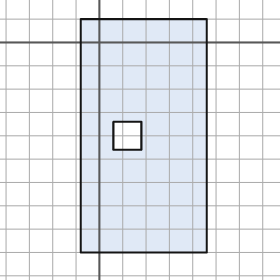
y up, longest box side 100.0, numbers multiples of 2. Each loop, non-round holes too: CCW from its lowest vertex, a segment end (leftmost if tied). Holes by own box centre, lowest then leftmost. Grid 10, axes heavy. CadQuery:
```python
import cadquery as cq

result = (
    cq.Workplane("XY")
    .moveTo(-8.0, -90.0)
    .lineTo(46.0, -90.0)
    .lineTo(46.0, 10.0)
    .lineTo(-8.0, 10.0)
    .close()
    .moveTo(6.0, -46.0)
    .lineTo(18.0, -46.0)
    .lineTo(18.0, -34.0)
    .lineTo(6.0, -34.0)
    .close()
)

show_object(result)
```